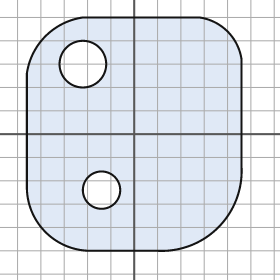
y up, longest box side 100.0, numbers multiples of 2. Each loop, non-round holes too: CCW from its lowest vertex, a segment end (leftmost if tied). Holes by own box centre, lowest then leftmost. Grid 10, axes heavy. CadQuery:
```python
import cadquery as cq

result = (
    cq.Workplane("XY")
    .moveTo(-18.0, -50.0)
    .lineTo(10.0, -50.0)
    .threePointArc((36.0, -40.0), (46.0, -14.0))
    .lineTo(46.0, 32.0)
    .threePointArc((40.0, 44.0), (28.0, 50.0))
    .lineTo(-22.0, 50.0)
    .threePointArc((-38.0, 42.0), (-46.0, 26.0))
    .lineTo(-46.0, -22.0)
    .threePointArc((-38.0, -42.0), (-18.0, -50.0))
    .close()
    .moveTo(-14.0, -24.0)
    .circle(8.0)
    .moveTo(-22.0, 30.0)
    .circle(10.0)
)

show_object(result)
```